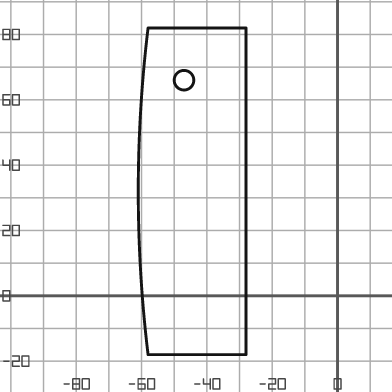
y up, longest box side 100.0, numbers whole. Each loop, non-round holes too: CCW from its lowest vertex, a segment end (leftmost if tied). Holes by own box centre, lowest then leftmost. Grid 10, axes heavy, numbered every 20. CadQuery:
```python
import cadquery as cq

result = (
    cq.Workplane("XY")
    .moveTo(-58.0, -18.0)
    .lineTo(-28.0, -18.0)
    .lineTo(-28.0, 82.0)
    .lineTo(-58.0, 82.0)
    .threePointArc((-61.0, 32.0), (-58.0, -18.0))
    .close()
    .moveTo(-47.0, 66.0)
    .circle(3.0)
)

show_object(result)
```